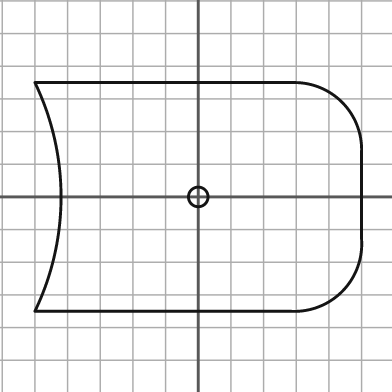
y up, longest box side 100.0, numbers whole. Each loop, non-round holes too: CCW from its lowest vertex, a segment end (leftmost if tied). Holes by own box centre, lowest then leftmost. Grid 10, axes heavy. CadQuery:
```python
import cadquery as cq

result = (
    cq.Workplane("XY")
    .moveTo(-50.0, -35.0)
    .lineTo(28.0, -35.0)
    .threePointArc((44.0, -29.0), (50.0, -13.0))
    .lineTo(50.0, 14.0)
    .threePointArc((44.0, 29.0), (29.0, 35.0))
    .lineTo(-50.0, 35.0)
    .threePointArc((-42.0, 0.0), (-50.0, -35.0))
    .close()
    .moveTo(0.0, 0.0)
    .circle(3.0)
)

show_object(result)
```